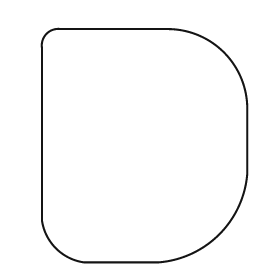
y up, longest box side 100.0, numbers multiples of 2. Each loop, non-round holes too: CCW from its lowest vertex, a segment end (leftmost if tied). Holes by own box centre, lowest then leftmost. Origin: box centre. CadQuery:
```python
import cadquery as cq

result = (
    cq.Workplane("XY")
    .moveTo(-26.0, -50.0)
    .lineTo(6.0, -50.0)
    .threePointArc((32.0, -38.0), (44.0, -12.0))
    .lineTo(44.0, 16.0)
    .threePointArc((34.0, 40.0), (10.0, 50.0))
    .lineTo(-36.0, 50.0)
    .threePointArc((-42.0, 48.0), (-44.0, 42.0))
    .lineTo(-44.0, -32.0)
    .threePointArc((-38.0, -44.0), (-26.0, -50.0))
    .close()
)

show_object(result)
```